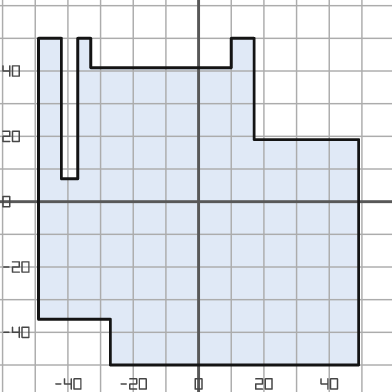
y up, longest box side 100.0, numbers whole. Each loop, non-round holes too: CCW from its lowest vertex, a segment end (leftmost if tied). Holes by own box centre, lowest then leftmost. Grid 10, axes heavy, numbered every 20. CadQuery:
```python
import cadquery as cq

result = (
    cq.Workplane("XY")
    .moveTo(-27.0, -50.0)
    .lineTo(49.0, -50.0)
    .lineTo(49.0, 19.0)
    .lineTo(17.0, 19.0)
    .lineTo(17.0, 50.0)
    .lineTo(10.0, 50.0)
    .lineTo(10.0, 41.0)
    .lineTo(-33.0, 41.0)
    .lineTo(-33.0, 50.0)
    .lineTo(-37.0, 50.0)
    .lineTo(-37.0, 7.0)
    .lineTo(-42.0, 7.0)
    .lineTo(-42.0, 50.0)
    .lineTo(-49.0, 50.0)
    .lineTo(-49.0, -36.0)
    .lineTo(-27.0, -36.0)
    .close()
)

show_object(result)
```